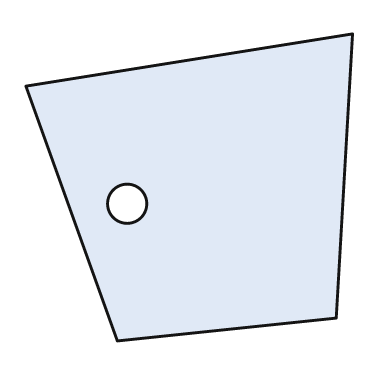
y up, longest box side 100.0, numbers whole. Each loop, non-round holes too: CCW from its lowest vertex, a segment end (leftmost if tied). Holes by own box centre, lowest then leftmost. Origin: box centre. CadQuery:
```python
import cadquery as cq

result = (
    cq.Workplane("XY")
    .moveTo(-22.0, -47.0)
    .lineTo(45.0, -40.0)
    .lineTo(50.0, 47.0)
    .lineTo(-50.0, 31.0)
    .close()
    .moveTo(-19.0, -5.0)
    .circle(6.0)
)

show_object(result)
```